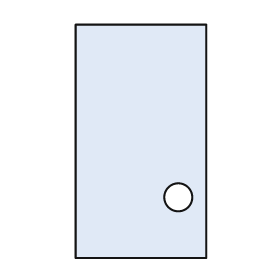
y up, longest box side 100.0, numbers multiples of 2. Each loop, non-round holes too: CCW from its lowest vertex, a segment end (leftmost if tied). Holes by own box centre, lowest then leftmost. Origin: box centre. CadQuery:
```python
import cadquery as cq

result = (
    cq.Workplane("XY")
    .moveTo(-28.0, -50.0)
    .lineTo(28.0, -50.0)
    .lineTo(28.0, 50.0)
    .lineTo(-28.0, 50.0)
    .close()
    .moveTo(16.0, -24.0)
    .circle(6.0)
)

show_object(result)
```